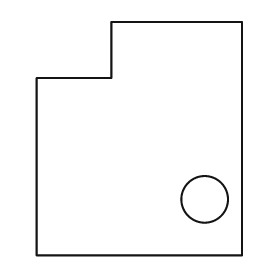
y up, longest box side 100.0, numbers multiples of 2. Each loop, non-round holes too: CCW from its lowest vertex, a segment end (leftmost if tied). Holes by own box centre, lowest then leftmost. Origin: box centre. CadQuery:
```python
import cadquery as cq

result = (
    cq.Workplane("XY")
    .moveTo(-44.0, -50.0)
    .lineTo(44.0, -50.0)
    .lineTo(44.0, 50.0)
    .lineTo(-12.0, 50.0)
    .lineTo(-12.0, 26.0)
    .lineTo(-44.0, 26.0)
    .close()
    .moveTo(28.0, -26.0)
    .circle(10.0)
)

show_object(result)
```